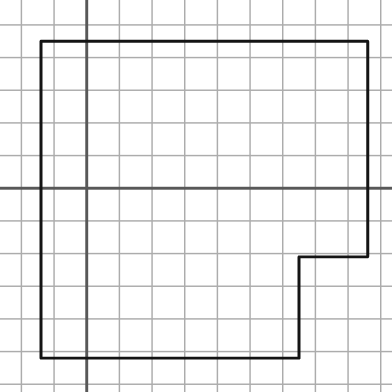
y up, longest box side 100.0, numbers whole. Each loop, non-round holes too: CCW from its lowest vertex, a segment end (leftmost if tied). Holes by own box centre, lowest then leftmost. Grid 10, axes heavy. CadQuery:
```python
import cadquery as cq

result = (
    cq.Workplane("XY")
    .moveTo(-14.0, -52.0)
    .lineTo(65.0, -52.0)
    .lineTo(65.0, -21.0)
    .lineTo(86.0, -21.0)
    .lineTo(86.0, 45.0)
    .lineTo(-14.0, 45.0)
    .close()
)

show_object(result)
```